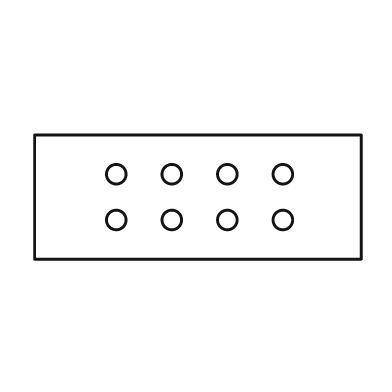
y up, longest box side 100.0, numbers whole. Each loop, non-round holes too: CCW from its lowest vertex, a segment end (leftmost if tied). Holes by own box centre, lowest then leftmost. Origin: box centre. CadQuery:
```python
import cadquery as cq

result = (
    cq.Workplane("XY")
    .moveTo(-50.0, -19.0)
    .lineTo(50.0, -19.0)
    .lineTo(50.0, 19.0)
    .lineTo(-50.0, 19.0)
    .close()
    .moveTo(-25.0, -7.0)
    .circle(3.0)
    .moveTo(-8.0, -7.0)
    .circle(3.0)
    .moveTo(9.0, -7.0)
    .circle(3.0)
    .moveTo(26.0, -7.0)
    .circle(3.0)
    .moveTo(-25.0, 7.0)
    .circle(3.0)
    .moveTo(-8.0, 7.0)
    .circle(3.0)
    .moveTo(9.0, 7.0)
    .circle(3.0)
    .moveTo(26.0, 7.0)
    .circle(3.0)
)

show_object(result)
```